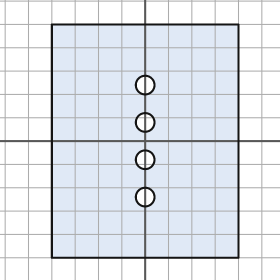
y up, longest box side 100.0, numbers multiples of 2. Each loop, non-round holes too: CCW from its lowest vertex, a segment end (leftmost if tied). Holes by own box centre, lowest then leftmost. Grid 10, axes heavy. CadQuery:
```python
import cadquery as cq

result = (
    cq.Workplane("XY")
    .moveTo(-40.0, -50.0)
    .lineTo(40.0, -50.0)
    .lineTo(40.0, 50.0)
    .lineTo(-40.0, 50.0)
    .close()
    .moveTo(0.0, -24.0)
    .circle(4.0)
    .moveTo(0.0, -8.0)
    .circle(4.0)
    .moveTo(0.0, 8.0)
    .circle(4.0)
    .moveTo(0.0, 24.0)
    .circle(4.0)
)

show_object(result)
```